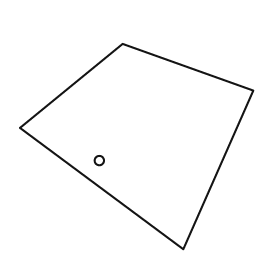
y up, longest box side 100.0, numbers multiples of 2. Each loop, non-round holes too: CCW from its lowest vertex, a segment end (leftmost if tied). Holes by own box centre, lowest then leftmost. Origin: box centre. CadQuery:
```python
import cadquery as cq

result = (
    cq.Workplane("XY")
    .moveTo(20.0, -44.0)
    .lineTo(50.0, 24.0)
    .lineTo(-6.0, 44.0)
    .lineTo(-50.0, 8.0)
    .close()
    .moveTo(-16.0, -6.0)
    .circle(2.0)
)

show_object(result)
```